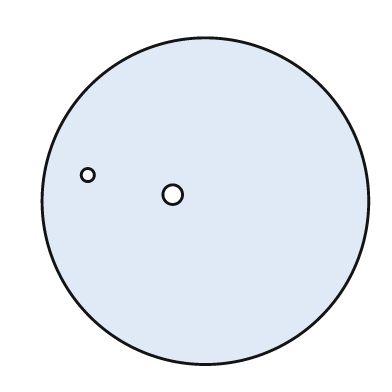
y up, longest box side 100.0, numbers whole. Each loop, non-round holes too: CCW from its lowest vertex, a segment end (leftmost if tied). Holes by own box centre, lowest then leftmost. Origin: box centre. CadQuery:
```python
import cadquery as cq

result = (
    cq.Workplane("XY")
    .moveTo(0.0, 0.0)
    .circle(50.0)
    .moveTo(-10.0, 2.0)
    .circle(3.0)
    .moveTo(-36.0, 8.0)
    .circle(2.0)
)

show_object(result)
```